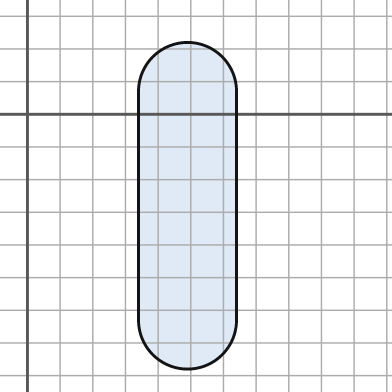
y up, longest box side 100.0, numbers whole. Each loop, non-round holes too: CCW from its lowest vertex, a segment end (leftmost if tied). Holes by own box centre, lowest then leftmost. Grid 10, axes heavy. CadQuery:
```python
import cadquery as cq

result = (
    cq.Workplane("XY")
    .moveTo(34.0, -63.0)
    .threePointArc((49.0, -78.0), (64.0, -63.0))
    .lineTo(64.0, 7.0)
    .threePointArc((49.0, 22.0), (34.0, 7.0))
    .close()
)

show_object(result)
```